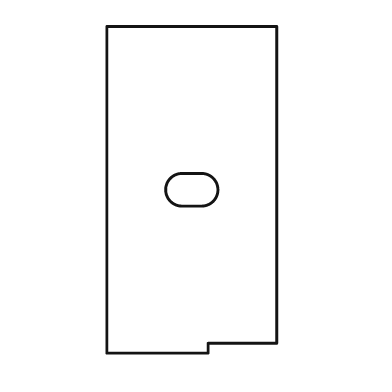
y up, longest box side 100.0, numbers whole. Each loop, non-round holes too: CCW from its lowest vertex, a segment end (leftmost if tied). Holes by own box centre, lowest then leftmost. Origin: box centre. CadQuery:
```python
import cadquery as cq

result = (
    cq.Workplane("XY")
    .moveTo(-26.0, -50.0)
    .lineTo(5.0, -50.0)
    .lineTo(5.0, -47.0)
    .lineTo(26.0, -47.0)
    .lineTo(26.0, 50.0)
    .lineTo(-26.0, 50.0)
    .close()
    .moveTo(-3.0, -5.0)
    .lineTo(3.0, -5.0)
    .threePointArc((8.0, 0.0), (3.0, 5.0))
    .lineTo(-3.0, 5.0)
    .threePointArc((-8.0, 0.0), (-3.0, -5.0))
    .close()
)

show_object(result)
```